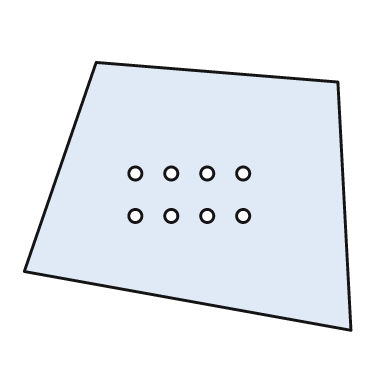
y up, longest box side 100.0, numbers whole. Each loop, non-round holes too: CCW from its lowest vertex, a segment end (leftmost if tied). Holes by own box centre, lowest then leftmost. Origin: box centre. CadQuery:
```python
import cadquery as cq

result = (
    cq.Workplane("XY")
    .moveTo(50.0, -41.0)
    .lineTo(46.0, 35.0)
    .lineTo(-28.0, 41.0)
    .lineTo(-50.0, -23.0)
    .close()
    .moveTo(-16.0, -6.0)
    .circle(2.0)
    .moveTo(-5.0, -6.0)
    .circle(2.0)
    .moveTo(6.0, -6.0)
    .circle(2.0)
    .moveTo(17.0, -6.0)
    .circle(2.0)
    .moveTo(-16.0, 7.0)
    .circle(2.0)
    .moveTo(-5.0, 7.0)
    .circle(2.0)
    .moveTo(6.0, 7.0)
    .circle(2.0)
    .moveTo(17.0, 7.0)
    .circle(2.0)
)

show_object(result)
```